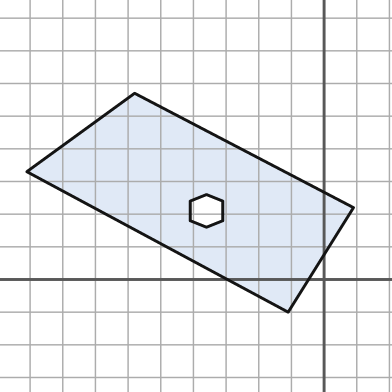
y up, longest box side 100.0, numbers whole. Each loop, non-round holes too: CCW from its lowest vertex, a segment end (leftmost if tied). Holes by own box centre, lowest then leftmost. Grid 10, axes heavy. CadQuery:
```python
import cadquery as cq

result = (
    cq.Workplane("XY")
    .moveTo(-11.0, -10.0)
    .lineTo(9.0, 22.0)
    .lineTo(-58.0, 57.0)
    .lineTo(-91.0, 33.0)
    .close()
    .moveTo(-36.0, 16.0)
    .lineTo(-31.0, 18.0)
    .lineTo(-31.0, 24.0)
    .lineTo(-36.0, 26.0)
    .lineTo(-41.0, 24.0)
    .lineTo(-41.0, 18.0)
    .close()
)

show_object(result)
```